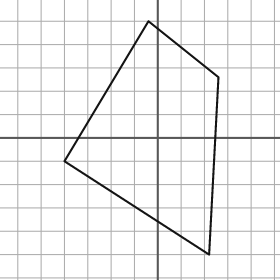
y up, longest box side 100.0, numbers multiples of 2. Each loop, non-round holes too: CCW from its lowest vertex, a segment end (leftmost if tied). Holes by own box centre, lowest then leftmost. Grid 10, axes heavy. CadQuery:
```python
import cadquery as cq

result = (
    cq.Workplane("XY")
    .moveTo(22.0, -50.0)
    .lineTo(26.0, 26.0)
    .lineTo(-4.0, 50.0)
    .lineTo(-40.0, -10.0)
    .close()
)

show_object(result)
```